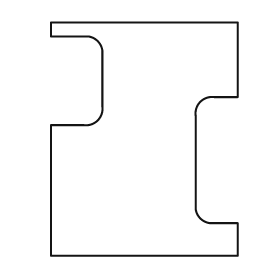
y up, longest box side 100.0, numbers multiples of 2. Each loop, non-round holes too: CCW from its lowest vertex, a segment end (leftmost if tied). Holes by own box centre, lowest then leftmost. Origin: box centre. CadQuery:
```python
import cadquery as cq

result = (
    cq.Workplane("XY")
    .moveTo(-40.0, -50.0)
    .lineTo(40.0, -50.0)
    .lineTo(40.0, -36.0)
    .lineTo(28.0, -36.0)
    .threePointArc((24.0, -34.0), (22.0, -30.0))
    .lineTo(22.0, 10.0)
    .threePointArc((24.0, 16.0), (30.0, 18.0))
    .lineTo(40.0, 18.0)
    .lineTo(40.0, 50.0)
    .lineTo(-40.0, 50.0)
    .lineTo(-40.0, 44.0)
    .lineTo(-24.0, 44.0)
    .threePointArc((-20.0, 42.0), (-18.0, 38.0))
    .lineTo(-18.0, 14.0)
    .threePointArc((-20.0, 8.0), (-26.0, 6.0))
    .lineTo(-40.0, 6.0)
    .close()
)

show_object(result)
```